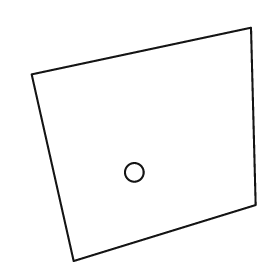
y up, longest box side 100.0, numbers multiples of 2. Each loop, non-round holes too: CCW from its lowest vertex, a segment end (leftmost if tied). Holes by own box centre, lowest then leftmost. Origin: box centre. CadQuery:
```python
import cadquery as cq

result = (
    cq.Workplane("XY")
    .moveTo(-30.0, -50.0)
    .lineTo(48.0, -26.0)
    .lineTo(46.0, 50.0)
    .lineTo(-48.0, 30.0)
    .close()
    .moveTo(-4.0, -12.0)
    .circle(4.0)
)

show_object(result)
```